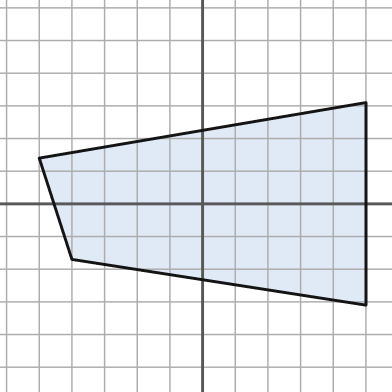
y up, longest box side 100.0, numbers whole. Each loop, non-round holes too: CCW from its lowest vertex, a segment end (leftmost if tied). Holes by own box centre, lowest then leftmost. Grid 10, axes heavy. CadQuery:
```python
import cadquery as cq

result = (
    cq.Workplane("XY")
    .moveTo(50.0, -31.0)
    .lineTo(50.0, 31.0)
    .lineTo(-50.0, 14.0)
    .lineTo(-40.0, -17.0)
    .close()
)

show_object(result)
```